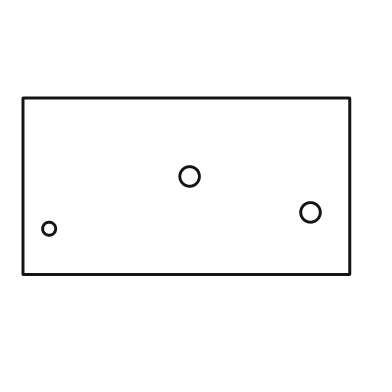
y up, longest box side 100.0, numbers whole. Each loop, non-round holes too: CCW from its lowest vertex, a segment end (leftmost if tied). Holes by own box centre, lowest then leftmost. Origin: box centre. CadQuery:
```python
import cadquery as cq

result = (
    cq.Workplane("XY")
    .moveTo(-50.0, -27.0)
    .lineTo(50.0, -27.0)
    .lineTo(50.0, 27.0)
    .lineTo(-50.0, 27.0)
    .close()
    .moveTo(-42.0, -13.0)
    .circle(2.0)
    .moveTo(38.0, -8.0)
    .circle(3.0)
    .moveTo(1.0, 3.0)
    .circle(3.0)
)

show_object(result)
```